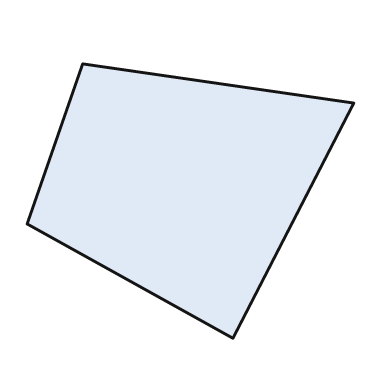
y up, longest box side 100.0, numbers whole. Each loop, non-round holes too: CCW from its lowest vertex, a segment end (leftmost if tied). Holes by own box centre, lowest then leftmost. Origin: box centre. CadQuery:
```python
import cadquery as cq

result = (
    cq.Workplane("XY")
    .moveTo(13.0, -42.0)
    .lineTo(50.0, 30.0)
    .lineTo(-33.0, 42.0)
    .lineTo(-50.0, -7.0)
    .close()
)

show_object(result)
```